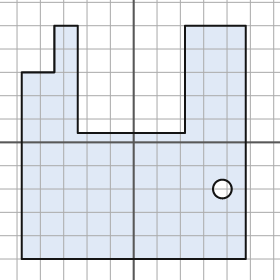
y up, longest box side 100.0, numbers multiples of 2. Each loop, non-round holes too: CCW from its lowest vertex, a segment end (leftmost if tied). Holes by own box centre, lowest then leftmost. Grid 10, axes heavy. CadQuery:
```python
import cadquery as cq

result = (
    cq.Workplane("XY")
    .moveTo(-48.0, -50.0)
    .lineTo(48.0, -50.0)
    .lineTo(48.0, 50.0)
    .lineTo(22.0, 50.0)
    .lineTo(22.0, 4.0)
    .lineTo(-24.0, 4.0)
    .lineTo(-24.0, 50.0)
    .lineTo(-34.0, 50.0)
    .lineTo(-34.0, 30.0)
    .lineTo(-48.0, 30.0)
    .close()
    .moveTo(38.0, -20.0)
    .circle(4.0)
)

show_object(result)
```